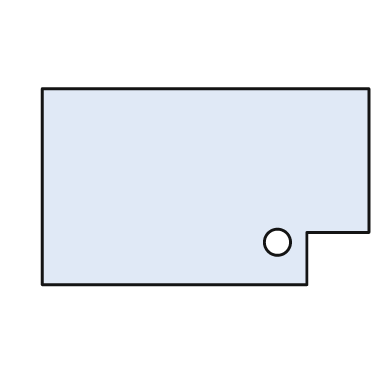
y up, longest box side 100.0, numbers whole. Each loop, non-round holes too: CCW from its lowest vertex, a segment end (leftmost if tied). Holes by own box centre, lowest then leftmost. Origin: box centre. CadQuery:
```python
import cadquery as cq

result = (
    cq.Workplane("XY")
    .moveTo(-50.0, -30.0)
    .lineTo(31.0, -30.0)
    .lineTo(31.0, -14.0)
    .lineTo(50.0, -14.0)
    .lineTo(50.0, 30.0)
    .lineTo(-50.0, 30.0)
    .close()
    .moveTo(22.0, -17.0)
    .circle(4.0)
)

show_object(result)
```